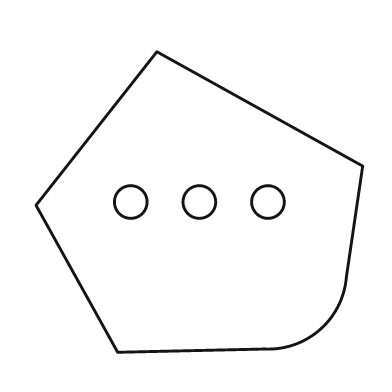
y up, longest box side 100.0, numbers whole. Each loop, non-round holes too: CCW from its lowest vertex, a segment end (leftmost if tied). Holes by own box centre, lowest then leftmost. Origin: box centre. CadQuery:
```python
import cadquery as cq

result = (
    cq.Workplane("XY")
    .moveTo(-25.0, -46.0)
    .lineTo(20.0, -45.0)
    .threePointArc((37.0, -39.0), (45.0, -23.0))
    .lineTo(50.0, 11.0)
    .lineTo(-13.0, 46.0)
    .lineTo(-50.0, -1.0)
    .close()
    .moveTo(-21.0, 0.0)
    .circle(5.0)
    .moveTo(0.0, 0.0)
    .circle(5.0)
    .moveTo(21.0, 0.0)
    .circle(5.0)
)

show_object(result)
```